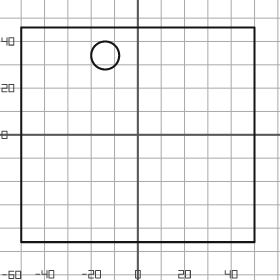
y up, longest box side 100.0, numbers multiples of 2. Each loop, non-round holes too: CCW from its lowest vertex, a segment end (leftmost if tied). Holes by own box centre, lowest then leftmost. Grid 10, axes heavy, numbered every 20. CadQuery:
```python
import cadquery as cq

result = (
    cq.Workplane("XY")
    .moveTo(-50.0, -46.0)
    .lineTo(50.0, -46.0)
    .lineTo(50.0, 46.0)
    .lineTo(-50.0, 46.0)
    .close()
    .moveTo(-14.0, 34.0)
    .circle(6.0)
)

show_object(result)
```